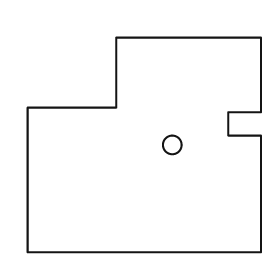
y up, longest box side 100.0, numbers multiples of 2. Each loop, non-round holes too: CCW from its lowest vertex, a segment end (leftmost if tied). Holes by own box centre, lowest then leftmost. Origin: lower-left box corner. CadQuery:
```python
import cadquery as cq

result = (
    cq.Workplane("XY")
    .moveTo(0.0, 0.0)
    .lineTo(100.0, 0.0)
    .lineTo(100.0, 50.0)
    .lineTo(86.0, 50.0)
    .lineTo(86.0, 60.0)
    .lineTo(100.0, 60.0)
    .lineTo(100.0, 92.0)
    .lineTo(38.0, 92.0)
    .lineTo(38.0, 62.0)
    .lineTo(0.0, 62.0)
    .close()
    .moveTo(62.0, 46.0)
    .circle(4.0)
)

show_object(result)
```